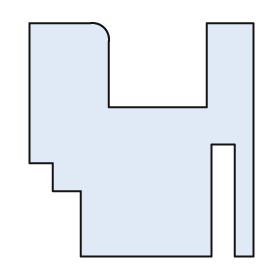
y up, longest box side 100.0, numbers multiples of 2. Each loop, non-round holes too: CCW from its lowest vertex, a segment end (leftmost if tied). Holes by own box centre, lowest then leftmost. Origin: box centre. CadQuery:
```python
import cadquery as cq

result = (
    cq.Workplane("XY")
    .moveTo(-26.0, -50.0)
    .lineTo(30.0, -50.0)
    .lineTo(30.0, -2.0)
    .lineTo(40.0, -2.0)
    .lineTo(40.0, -50.0)
    .lineTo(48.0, -50.0)
    .lineTo(48.0, 50.0)
    .lineTo(28.0, 50.0)
    .lineTo(28.0, 14.0)
    .lineTo(-14.0, 14.0)
    .lineTo(-14.0, 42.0)
    .threePointArc((-16.0, 48.0), (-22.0, 50.0))
    .lineTo(-48.0, 50.0)
    .lineTo(-48.0, -10.0)
    .lineTo(-38.0, -10.0)
    .lineTo(-38.0, -22.0)
    .lineTo(-26.0, -22.0)
    .close()
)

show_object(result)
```